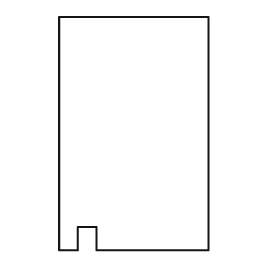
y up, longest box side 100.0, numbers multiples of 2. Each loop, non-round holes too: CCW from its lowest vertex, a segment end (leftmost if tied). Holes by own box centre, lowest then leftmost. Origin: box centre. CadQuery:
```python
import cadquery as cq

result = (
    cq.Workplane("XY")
    .moveTo(-32.0, -50.0)
    .lineTo(-24.0, -50.0)
    .lineTo(-24.0, -40.0)
    .lineTo(-16.0, -40.0)
    .lineTo(-16.0, -50.0)
    .lineTo(32.0, -50.0)
    .lineTo(32.0, 50.0)
    .lineTo(-32.0, 50.0)
    .close()
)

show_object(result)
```